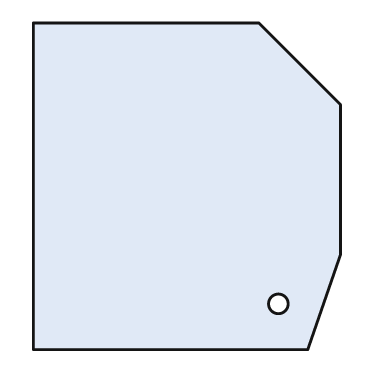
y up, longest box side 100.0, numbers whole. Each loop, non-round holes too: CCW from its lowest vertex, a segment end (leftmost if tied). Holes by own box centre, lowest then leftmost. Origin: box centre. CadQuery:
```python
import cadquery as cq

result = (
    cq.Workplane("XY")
    .moveTo(-47.0, -50.0)
    .lineTo(37.0, -50.0)
    .lineTo(47.0, -21.0)
    .lineTo(47.0, 25.0)
    .lineTo(22.0, 50.0)
    .lineTo(-47.0, 50.0)
    .close()
    .moveTo(28.0, -36.0)
    .circle(3.0)
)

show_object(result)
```